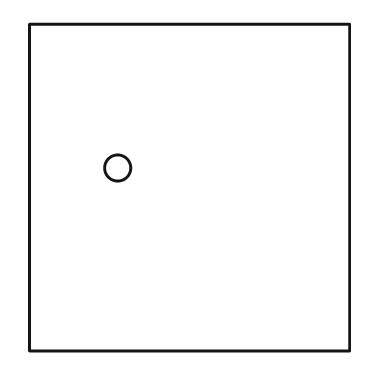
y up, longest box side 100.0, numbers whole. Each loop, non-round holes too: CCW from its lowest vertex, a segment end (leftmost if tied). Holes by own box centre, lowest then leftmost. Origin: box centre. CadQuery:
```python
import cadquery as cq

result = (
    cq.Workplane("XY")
    .moveTo(-49.0, -50.0)
    .lineTo(49.0, -50.0)
    .lineTo(49.0, 50.0)
    .lineTo(-49.0, 50.0)
    .close()
    .moveTo(-22.0, 6.0)
    .circle(4.0)
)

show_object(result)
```